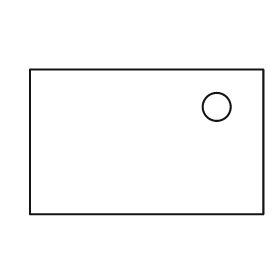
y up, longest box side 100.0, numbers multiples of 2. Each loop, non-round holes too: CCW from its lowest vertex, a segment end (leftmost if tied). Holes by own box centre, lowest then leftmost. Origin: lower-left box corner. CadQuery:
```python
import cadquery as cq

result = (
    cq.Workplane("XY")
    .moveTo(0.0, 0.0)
    .lineTo(100.0, 0.0)
    .lineTo(100.0, 62.0)
    .lineTo(0.0, 62.0)
    .close()
    .moveTo(80.0, 46.0)
    .circle(6.0)
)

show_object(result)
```